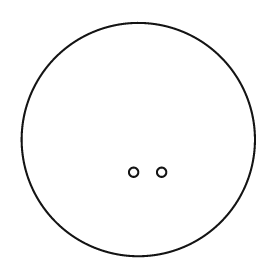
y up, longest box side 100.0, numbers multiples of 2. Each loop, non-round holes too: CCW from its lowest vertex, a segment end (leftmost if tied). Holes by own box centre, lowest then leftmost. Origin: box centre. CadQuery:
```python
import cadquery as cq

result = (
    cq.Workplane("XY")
    .moveTo(0.0, 0.0)
    .circle(50.0)
    .moveTo(-2.0, -14.0)
    .circle(2.0)
    .moveTo(10.0, -14.0)
    .circle(2.0)
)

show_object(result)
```